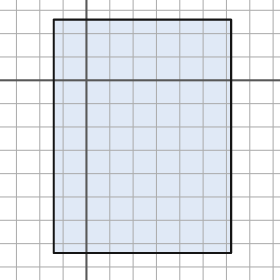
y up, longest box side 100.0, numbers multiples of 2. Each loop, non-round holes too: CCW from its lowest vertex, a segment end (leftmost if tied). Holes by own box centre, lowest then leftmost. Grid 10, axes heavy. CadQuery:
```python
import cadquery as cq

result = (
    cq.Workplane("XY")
    .moveTo(-14.0, -74.0)
    .lineTo(62.0, -74.0)
    .lineTo(62.0, 26.0)
    .lineTo(-14.0, 26.0)
    .close()
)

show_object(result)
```